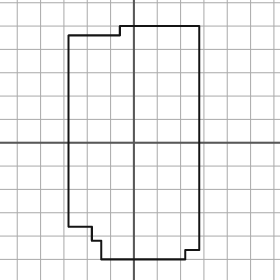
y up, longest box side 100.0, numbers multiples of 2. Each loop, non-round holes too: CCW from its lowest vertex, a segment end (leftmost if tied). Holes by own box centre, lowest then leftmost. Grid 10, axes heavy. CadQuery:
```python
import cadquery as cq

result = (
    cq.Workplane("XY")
    .moveTo(-14.0, -50.0)
    .lineTo(22.0, -50.0)
    .lineTo(22.0, -46.0)
    .lineTo(28.0, -46.0)
    .lineTo(28.0, 50.0)
    .lineTo(-6.0, 50.0)
    .lineTo(-6.0, 46.0)
    .lineTo(-28.0, 46.0)
    .lineTo(-28.0, -36.0)
    .lineTo(-18.0, -36.0)
    .lineTo(-18.0, -42.0)
    .lineTo(-14.0, -42.0)
    .close()
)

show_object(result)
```